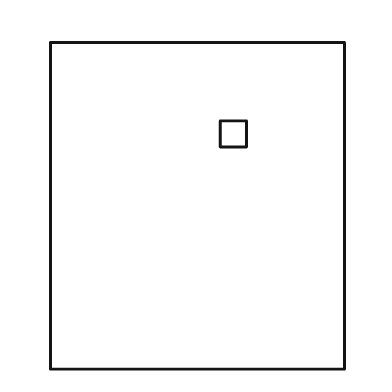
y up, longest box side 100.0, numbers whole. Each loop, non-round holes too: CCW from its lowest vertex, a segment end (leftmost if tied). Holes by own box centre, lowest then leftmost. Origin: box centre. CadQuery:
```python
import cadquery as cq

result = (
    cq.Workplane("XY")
    .moveTo(-45.0, -50.0)
    .lineTo(45.0, -50.0)
    .lineTo(45.0, 50.0)
    .lineTo(-45.0, 50.0)
    .close()
    .moveTo(7.0, 18.0)
    .lineTo(15.0, 18.0)
    .lineTo(15.0, 26.0)
    .lineTo(7.0, 26.0)
    .close()
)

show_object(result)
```